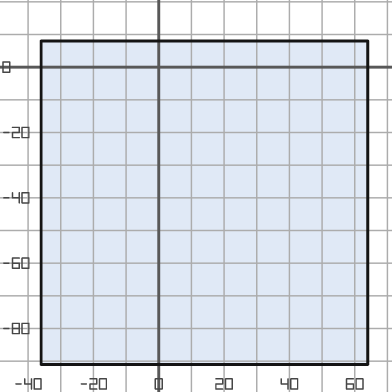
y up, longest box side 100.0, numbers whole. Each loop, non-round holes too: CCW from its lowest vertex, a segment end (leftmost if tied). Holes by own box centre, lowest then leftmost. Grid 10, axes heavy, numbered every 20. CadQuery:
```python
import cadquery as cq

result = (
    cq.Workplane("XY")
    .moveTo(-36.0, -91.0)
    .lineTo(64.0, -91.0)
    .lineTo(64.0, 8.0)
    .lineTo(-36.0, 8.0)
    .close()
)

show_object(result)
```